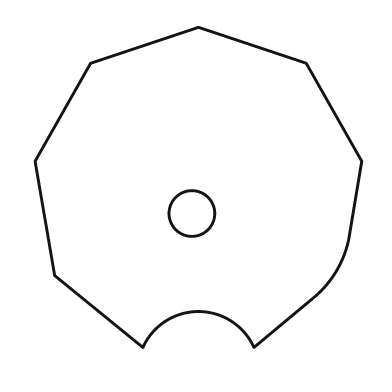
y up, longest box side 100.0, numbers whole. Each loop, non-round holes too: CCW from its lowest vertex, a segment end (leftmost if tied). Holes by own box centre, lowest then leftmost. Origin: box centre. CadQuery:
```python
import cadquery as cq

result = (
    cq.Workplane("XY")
    .moveTo(-17.0, -49.0)
    .threePointArc((0.0, -38.0), (17.0, -49.0))
    .lineTo(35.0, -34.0)
    .threePointArc((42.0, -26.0), (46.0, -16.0))
    .lineTo(50.0, 8.0)
    .lineTo(33.0, 38.0)
    .lineTo(0.0, 49.0)
    .lineTo(-33.0, 38.0)
    .lineTo(-50.0, 8.0)
    .lineTo(-44.0, -27.0)
    .close()
    .moveTo(-2.0, -8.0)
    .circle(7.0)
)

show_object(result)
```